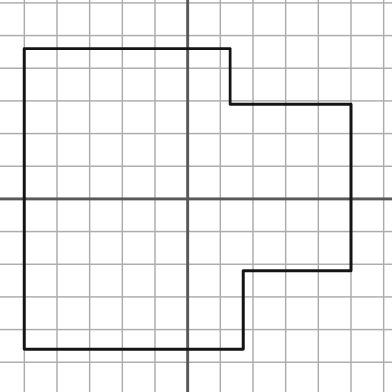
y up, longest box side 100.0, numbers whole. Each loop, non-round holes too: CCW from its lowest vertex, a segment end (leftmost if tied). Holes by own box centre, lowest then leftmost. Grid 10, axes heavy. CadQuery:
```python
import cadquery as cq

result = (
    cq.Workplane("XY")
    .moveTo(-50.0, -46.0)
    .lineTo(17.0, -46.0)
    .lineTo(17.0, -22.0)
    .lineTo(50.0, -22.0)
    .lineTo(50.0, 29.0)
    .lineTo(13.0, 29.0)
    .lineTo(13.0, 46.0)
    .lineTo(-50.0, 46.0)
    .close()
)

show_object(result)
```